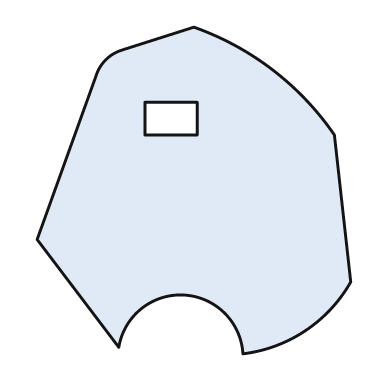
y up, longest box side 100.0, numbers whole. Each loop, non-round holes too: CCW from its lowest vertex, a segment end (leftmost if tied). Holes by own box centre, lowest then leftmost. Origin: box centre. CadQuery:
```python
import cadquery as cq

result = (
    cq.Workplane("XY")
    .moveTo(15.0, -50.0)
    .threePointArc((34.0, -43.0), (48.0, -28.0))
    .lineTo(43.0, 17.0)
    .threePointArc((24.0, 37.0), (0.0, 50.0))
    .lineTo(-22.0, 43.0)
    .threePointArc((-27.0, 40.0), (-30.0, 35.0))
    .lineTo(-48.0, -15.0)
    .lineTo(-23.0, -48.0)
    .threePointArc((-3.0, -32.0), (15.0, -50.0))
    .close()
    .moveTo(-15.0, 17.0)
    .lineTo(1.0, 17.0)
    .lineTo(1.0, 27.0)
    .lineTo(-15.0, 27.0)
    .close()
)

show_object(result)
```